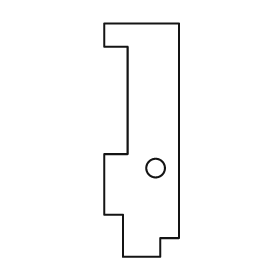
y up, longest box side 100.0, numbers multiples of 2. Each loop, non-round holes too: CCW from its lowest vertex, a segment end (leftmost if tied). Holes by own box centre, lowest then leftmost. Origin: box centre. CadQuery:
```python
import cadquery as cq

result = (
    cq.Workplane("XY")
    .moveTo(-8.0, -50.0)
    .lineTo(8.0, -50.0)
    .lineTo(8.0, -42.0)
    .lineTo(16.0, -42.0)
    .lineTo(16.0, 50.0)
    .lineTo(-16.0, 50.0)
    .lineTo(-16.0, 40.0)
    .lineTo(-6.0, 40.0)
    .lineTo(-6.0, -6.0)
    .lineTo(-16.0, -6.0)
    .lineTo(-16.0, -32.0)
    .lineTo(-8.0, -32.0)
    .close()
    .moveTo(6.0, -12.0)
    .circle(4.0)
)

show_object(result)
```